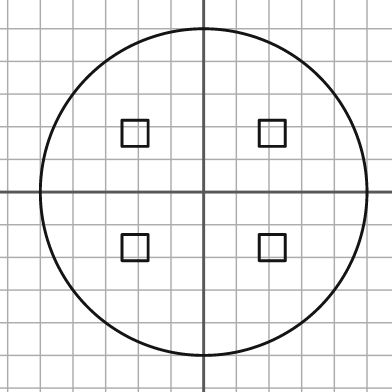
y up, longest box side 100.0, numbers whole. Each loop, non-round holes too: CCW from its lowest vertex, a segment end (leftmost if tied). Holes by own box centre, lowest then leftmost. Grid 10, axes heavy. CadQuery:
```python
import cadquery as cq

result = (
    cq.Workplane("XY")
    .moveTo(0.0, 0.0)
    .circle(50.0)
    .moveTo(-25.0, -21.0)
    .lineTo(-17.0, -21.0)
    .lineTo(-17.0, -13.0)
    .lineTo(-25.0, -13.0)
    .close()
    .moveTo(17.0, -21.0)
    .lineTo(25.0, -21.0)
    .lineTo(25.0, -13.0)
    .lineTo(17.0, -13.0)
    .close()
    .moveTo(-25.0, 14.0)
    .lineTo(-17.0, 14.0)
    .lineTo(-17.0, 22.0)
    .lineTo(-25.0, 22.0)
    .close()
    .moveTo(17.0, 14.0)
    .lineTo(25.0, 14.0)
    .lineTo(25.0, 22.0)
    .lineTo(17.0, 22.0)
    .close()
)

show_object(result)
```